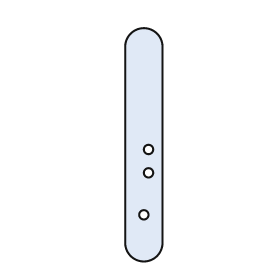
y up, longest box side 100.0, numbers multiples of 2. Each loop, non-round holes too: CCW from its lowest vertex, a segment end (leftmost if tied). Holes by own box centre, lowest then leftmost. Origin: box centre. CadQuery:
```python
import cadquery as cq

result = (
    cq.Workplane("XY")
    .moveTo(-8.0, -42.0)
    .threePointArc((0.0, -50.0), (8.0, -42.0))
    .lineTo(8.0, 42.0)
    .threePointArc((0.0, 50.0), (-8.0, 42.0))
    .close()
    .moveTo(0.0, -30.0)
    .circle(2.0)
    .moveTo(2.0, -12.0)
    .circle(2.0)
    .moveTo(2.0, -2.0)
    .circle(2.0)
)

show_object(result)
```